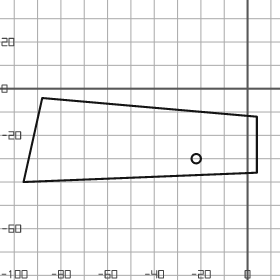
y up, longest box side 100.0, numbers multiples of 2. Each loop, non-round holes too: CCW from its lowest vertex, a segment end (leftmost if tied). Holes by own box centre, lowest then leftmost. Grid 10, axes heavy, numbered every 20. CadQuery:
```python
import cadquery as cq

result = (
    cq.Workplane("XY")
    .moveTo(-96.0, -40.0)
    .lineTo(4.0, -36.0)
    .lineTo(4.0, -12.0)
    .lineTo(-88.0, -4.0)
    .close()
    .moveTo(-22.0, -30.0)
    .circle(2.0)
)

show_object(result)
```